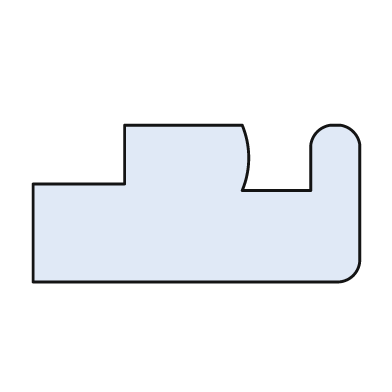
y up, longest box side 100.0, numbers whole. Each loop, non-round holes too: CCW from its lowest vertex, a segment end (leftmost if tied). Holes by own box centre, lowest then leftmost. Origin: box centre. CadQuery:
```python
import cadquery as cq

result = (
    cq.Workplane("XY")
    .moveTo(-50.0, -24.0)
    .lineTo(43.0, -24.0)
    .threePointArc((48.0, -22.0), (50.0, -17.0))
    .lineTo(50.0, 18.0)
    .threePointArc((48.0, 22.0), (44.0, 24.0))
    .lineTo(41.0, 24.0)
    .threePointArc((37.0, 22.0), (35.0, 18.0))
    .lineTo(35.0, 4.0)
    .lineTo(14.0, 4.0)
    .threePointArc((16.0, 14.0), (14.0, 24.0))
    .lineTo(-22.0, 24.0)
    .lineTo(-22.0, 6.0)
    .lineTo(-50.0, 6.0)
    .close()
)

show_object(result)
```